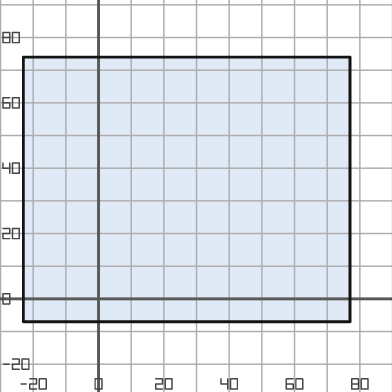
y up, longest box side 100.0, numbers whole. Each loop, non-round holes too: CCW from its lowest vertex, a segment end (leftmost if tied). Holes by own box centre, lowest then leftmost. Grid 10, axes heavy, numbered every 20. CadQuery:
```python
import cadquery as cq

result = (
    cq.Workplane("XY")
    .moveTo(-23.0, -7.0)
    .lineTo(77.0, -7.0)
    .lineTo(77.0, 74.0)
    .lineTo(-23.0, 74.0)
    .close()
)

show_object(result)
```